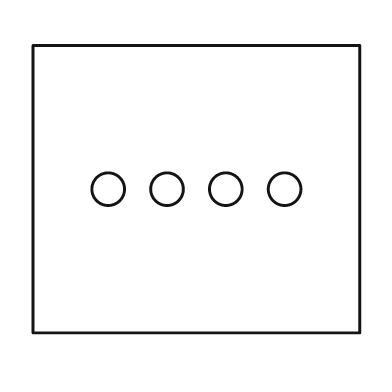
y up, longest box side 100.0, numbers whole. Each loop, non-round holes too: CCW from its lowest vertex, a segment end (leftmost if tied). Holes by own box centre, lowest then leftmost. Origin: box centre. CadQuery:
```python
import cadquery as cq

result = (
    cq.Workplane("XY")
    .moveTo(-50.0, -44.0)
    .lineTo(50.0, -44.0)
    .lineTo(50.0, 44.0)
    .lineTo(-50.0, 44.0)
    .close()
    .moveTo(-27.0, 0.0)
    .circle(5.0)
    .moveTo(-9.0, 0.0)
    .circle(5.0)
    .moveTo(9.0, 0.0)
    .circle(5.0)
    .moveTo(27.0, 0.0)
    .circle(5.0)
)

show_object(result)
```